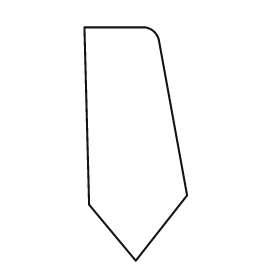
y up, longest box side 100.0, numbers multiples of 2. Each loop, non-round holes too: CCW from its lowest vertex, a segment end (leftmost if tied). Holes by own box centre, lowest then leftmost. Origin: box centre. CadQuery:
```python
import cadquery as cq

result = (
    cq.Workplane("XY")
    .moveTo(0.0, -50.0)
    .lineTo(22.0, -22.0)
    .lineTo(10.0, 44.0)
    .threePointArc((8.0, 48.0), (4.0, 50.0))
    .lineTo(-22.0, 50.0)
    .lineTo(-20.0, -26.0)
    .close()
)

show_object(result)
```